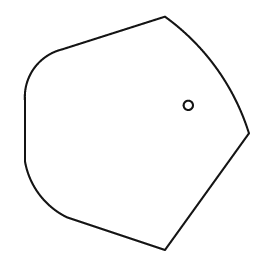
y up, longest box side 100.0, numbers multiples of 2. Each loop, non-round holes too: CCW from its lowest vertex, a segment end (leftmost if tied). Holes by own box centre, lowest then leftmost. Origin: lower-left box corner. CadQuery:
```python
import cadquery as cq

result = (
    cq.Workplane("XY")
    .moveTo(60.0, 0.0)
    .lineTo(96.0, 50.0)
    .threePointArc((82.0, 78.0), (60.0, 100.0))
    .lineTo(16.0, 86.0)
    .threePointArc((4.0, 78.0), (0.0, 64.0))
    .lineTo(0.0, 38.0)
    .threePointArc((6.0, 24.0), (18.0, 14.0))
    .close()
    .moveTo(70.0, 62.0)
    .circle(2.0)
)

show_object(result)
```